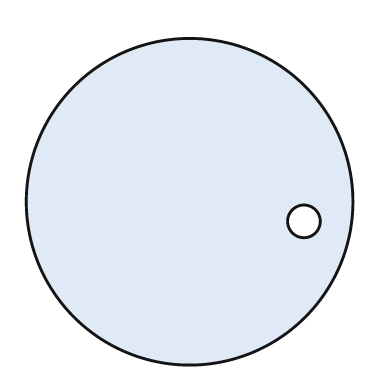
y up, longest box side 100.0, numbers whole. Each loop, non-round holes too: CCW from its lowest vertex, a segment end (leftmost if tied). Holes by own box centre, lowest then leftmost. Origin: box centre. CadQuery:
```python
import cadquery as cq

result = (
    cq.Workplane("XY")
    .moveTo(0.0, 0.0)
    .circle(50.0)
    .moveTo(35.0, -6.0)
    .circle(5.0)
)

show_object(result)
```